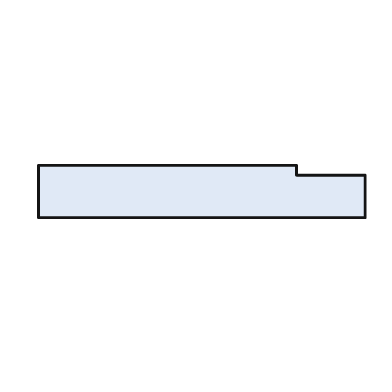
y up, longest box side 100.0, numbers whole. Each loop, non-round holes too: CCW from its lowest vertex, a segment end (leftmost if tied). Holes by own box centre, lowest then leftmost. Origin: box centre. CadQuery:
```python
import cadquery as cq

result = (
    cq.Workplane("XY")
    .moveTo(-50.0, -8.0)
    .lineTo(50.0, -8.0)
    .lineTo(50.0, 5.0)
    .lineTo(29.0, 5.0)
    .lineTo(29.0, 8.0)
    .lineTo(-50.0, 8.0)
    .close()
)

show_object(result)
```